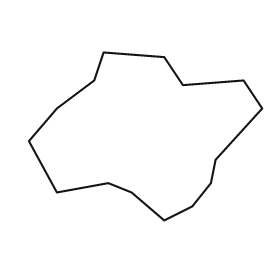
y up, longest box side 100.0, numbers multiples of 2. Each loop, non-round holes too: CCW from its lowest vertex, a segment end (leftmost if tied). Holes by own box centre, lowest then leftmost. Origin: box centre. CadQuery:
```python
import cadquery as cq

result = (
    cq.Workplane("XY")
    .moveTo(8.0, -36.0)
    .lineTo(20.0, -30.0)
    .lineTo(28.0, -20.0)
    .lineTo(30.0, -10.0)
    .lineTo(50.0, 12.0)
    .lineTo(42.0, 24.0)
    .lineTo(16.0, 22.0)
    .lineTo(8.0, 34.0)
    .lineTo(-18.0, 36.0)
    .lineTo(-22.0, 24.0)
    .lineTo(-38.0, 12.0)
    .lineTo(-50.0, -2.0)
    .lineTo(-38.0, -24.0)
    .lineTo(-16.0, -20.0)
    .lineTo(-6.0, -24.0)
    .close()
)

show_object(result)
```